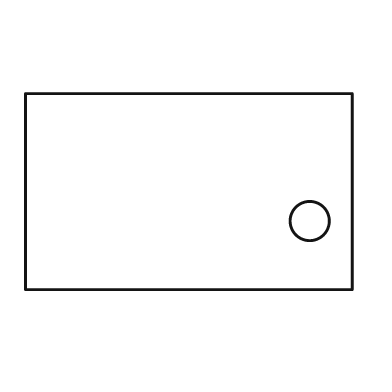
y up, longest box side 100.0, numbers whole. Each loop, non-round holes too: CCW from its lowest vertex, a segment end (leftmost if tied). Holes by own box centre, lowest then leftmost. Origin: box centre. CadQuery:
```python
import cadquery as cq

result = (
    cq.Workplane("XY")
    .moveTo(-50.0, -30.0)
    .lineTo(50.0, -30.0)
    .lineTo(50.0, 30.0)
    .lineTo(-50.0, 30.0)
    .close()
    .moveTo(37.0, -9.0)
    .circle(6.0)
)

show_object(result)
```